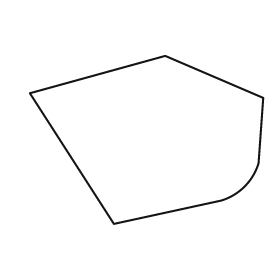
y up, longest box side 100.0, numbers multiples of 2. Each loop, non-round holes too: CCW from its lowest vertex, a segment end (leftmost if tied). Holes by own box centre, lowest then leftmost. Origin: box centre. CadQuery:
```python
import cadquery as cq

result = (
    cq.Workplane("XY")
    .moveTo(-14.0, -36.0)
    .lineTo(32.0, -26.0)
    .threePointArc((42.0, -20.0), (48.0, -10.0))
    .lineTo(50.0, 18.0)
    .lineTo(8.0, 36.0)
    .lineTo(-50.0, 20.0)
    .close()
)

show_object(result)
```